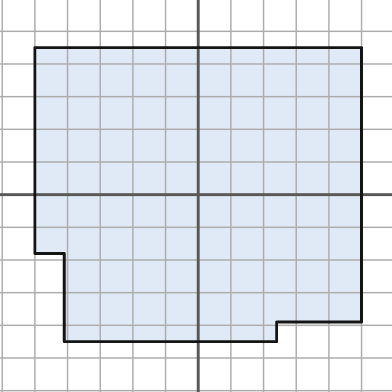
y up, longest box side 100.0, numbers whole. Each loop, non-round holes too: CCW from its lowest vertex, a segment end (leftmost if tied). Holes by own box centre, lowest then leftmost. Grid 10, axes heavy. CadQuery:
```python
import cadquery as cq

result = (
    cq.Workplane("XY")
    .moveTo(-41.0, -45.0)
    .lineTo(24.0, -45.0)
    .lineTo(24.0, -39.0)
    .lineTo(50.0, -39.0)
    .lineTo(50.0, 45.0)
    .lineTo(-50.0, 45.0)
    .lineTo(-50.0, -18.0)
    .lineTo(-41.0, -18.0)
    .close()
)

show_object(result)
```